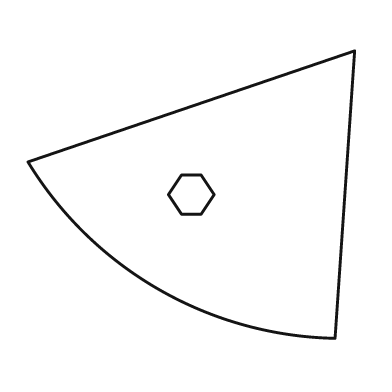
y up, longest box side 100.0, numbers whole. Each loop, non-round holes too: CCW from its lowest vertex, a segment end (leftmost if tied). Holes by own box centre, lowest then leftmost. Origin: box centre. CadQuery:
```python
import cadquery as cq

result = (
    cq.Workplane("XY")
    .moveTo(44.0, -44.0)
    .lineTo(50.0, 44.0)
    .lineTo(-50.0, 10.0)
    .threePointArc((-10.0, -29.0), (44.0, -44.0))
    .close()
    .moveTo(-3.0, -6.0)
    .lineTo(3.0, -6.0)
    .lineTo(7.0, 0.0)
    .lineTo(3.0, 6.0)
    .lineTo(-3.0, 6.0)
    .lineTo(-7.0, 0.0)
    .close()
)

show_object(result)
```